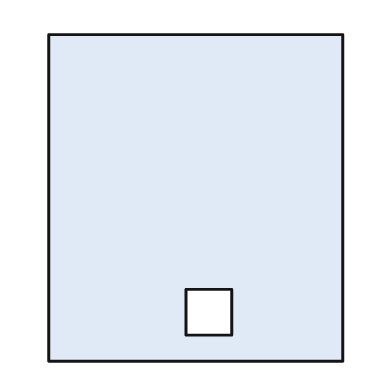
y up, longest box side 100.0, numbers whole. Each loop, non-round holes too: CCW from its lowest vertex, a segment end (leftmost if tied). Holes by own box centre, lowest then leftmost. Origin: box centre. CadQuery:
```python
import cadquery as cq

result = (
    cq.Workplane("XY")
    .moveTo(-45.0, -50.0)
    .lineTo(45.0, -50.0)
    .lineTo(45.0, 50.0)
    .lineTo(-45.0, 50.0)
    .close()
    .moveTo(-3.0, -42.0)
    .lineTo(11.0, -42.0)
    .lineTo(11.0, -28.0)
    .lineTo(-3.0, -28.0)
    .close()
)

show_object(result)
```